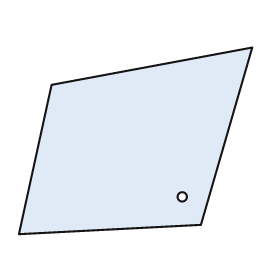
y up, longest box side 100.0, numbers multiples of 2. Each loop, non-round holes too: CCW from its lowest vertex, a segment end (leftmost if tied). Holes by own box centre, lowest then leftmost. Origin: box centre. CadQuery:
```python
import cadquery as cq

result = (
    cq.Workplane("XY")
    .moveTo(-50.0, -40.0)
    .lineTo(28.0, -36.0)
    .lineTo(50.0, 40.0)
    .lineTo(-36.0, 24.0)
    .close()
    .moveTo(20.0, -24.0)
    .circle(2.0)
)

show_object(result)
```